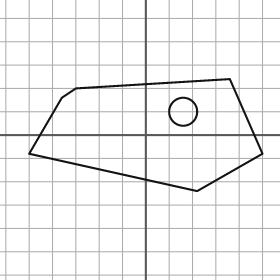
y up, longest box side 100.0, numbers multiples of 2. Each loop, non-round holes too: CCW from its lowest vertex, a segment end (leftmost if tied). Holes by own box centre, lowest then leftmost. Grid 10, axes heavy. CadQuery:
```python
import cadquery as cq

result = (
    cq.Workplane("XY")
    .moveTo(22.0, -24.0)
    .lineTo(50.0, -8.0)
    .lineTo(36.0, 24.0)
    .lineTo(-30.0, 20.0)
    .lineTo(-36.0, 16.0)
    .lineTo(-50.0, -8.0)
    .close()
    .moveTo(16.0, 10.0)
    .circle(6.0)
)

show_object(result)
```